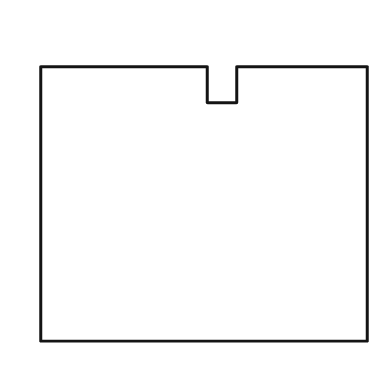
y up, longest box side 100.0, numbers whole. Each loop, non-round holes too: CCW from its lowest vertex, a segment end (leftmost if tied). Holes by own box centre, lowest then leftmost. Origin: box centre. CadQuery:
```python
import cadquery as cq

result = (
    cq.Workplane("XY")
    .moveTo(-50.0, -42.0)
    .lineTo(50.0, -42.0)
    .lineTo(50.0, 42.0)
    .lineTo(10.0, 42.0)
    .lineTo(10.0, 31.0)
    .lineTo(1.0, 31.0)
    .lineTo(1.0, 42.0)
    .lineTo(-50.0, 42.0)
    .close()
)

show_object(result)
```